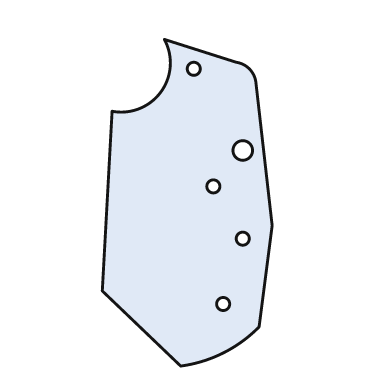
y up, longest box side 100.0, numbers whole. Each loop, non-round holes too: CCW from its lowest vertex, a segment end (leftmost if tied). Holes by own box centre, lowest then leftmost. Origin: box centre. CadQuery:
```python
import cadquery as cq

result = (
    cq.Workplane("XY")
    .moveTo(-2.0, -50.0)
    .threePointArc((11.0, -46.0), (22.0, -38.0))
    .lineTo(26.0, -7.0)
    .lineTo(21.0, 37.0)
    .threePointArc((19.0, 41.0), (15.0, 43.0))
    .lineTo(-7.0, 50.0)
    .threePointArc((-8.0, 34.0), (-23.0, 28.0))
    .lineTo(-26.0, -27.0)
    .close()
    .moveTo(11.0, -31.0)
    .circle(2.0)
    .moveTo(17.0, -11.0)
    .circle(2.0)
    .moveTo(8.0, 5.0)
    .circle(2.0)
    .moveTo(17.0, 16.0)
    .circle(3.0)
    .moveTo(2.0, 41.0)
    .circle(2.0)
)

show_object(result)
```